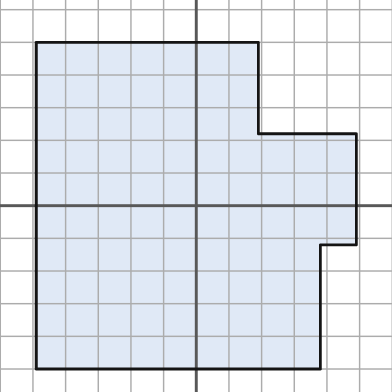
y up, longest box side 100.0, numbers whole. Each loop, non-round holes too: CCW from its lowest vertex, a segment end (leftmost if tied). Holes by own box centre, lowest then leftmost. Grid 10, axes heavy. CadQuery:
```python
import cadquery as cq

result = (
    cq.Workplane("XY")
    .moveTo(-49.0, -50.0)
    .lineTo(38.0, -50.0)
    .lineTo(38.0, -12.0)
    .lineTo(49.0, -12.0)
    .lineTo(49.0, 22.0)
    .lineTo(19.0, 22.0)
    .lineTo(19.0, 50.0)
    .lineTo(-49.0, 50.0)
    .close()
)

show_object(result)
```